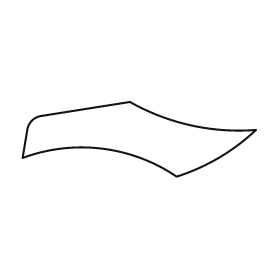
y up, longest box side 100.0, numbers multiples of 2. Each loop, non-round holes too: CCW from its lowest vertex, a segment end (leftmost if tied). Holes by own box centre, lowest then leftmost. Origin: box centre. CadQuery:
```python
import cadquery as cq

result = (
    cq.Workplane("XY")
    .moveTo(16.0, -16.0)
    .threePointArc((34.0, -8.0), (50.0, 4.0))
    .threePointArc((22.0, 6.0), (-4.0, 16.0))
    .lineTo(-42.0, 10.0)
    .threePointArc((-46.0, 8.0), (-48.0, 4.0))
    .lineTo(-50.0, -8.0)
    .threePointArc((-16.0, -4.0), (16.0, -16.0))
    .close()
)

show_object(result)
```